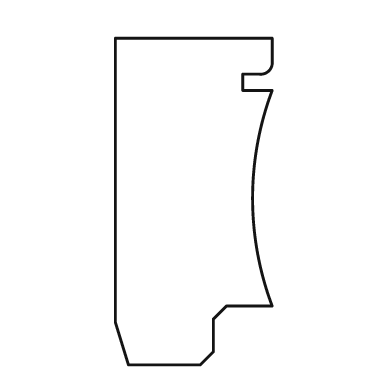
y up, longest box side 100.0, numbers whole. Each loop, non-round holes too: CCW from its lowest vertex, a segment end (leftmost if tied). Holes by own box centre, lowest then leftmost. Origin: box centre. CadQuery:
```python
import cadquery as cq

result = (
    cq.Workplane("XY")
    .moveTo(-20.0, -50.0)
    .lineTo(2.0, -50.0)
    .lineTo(6.0, -46.0)
    .lineTo(6.0, -36.0)
    .lineTo(10.0, -32.0)
    .lineTo(24.0, -32.0)
    .threePointArc((18.0, 1.0), (24.0, 34.0))
    .lineTo(15.0, 34.0)
    .lineTo(15.0, 39.0)
    .lineTo(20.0, 39.0)
    .threePointArc((23.0, 40.0), (24.0, 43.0))
    .lineTo(24.0, 50.0)
    .lineTo(-24.0, 50.0)
    .lineTo(-24.0, -37.0)
    .close()
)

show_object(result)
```